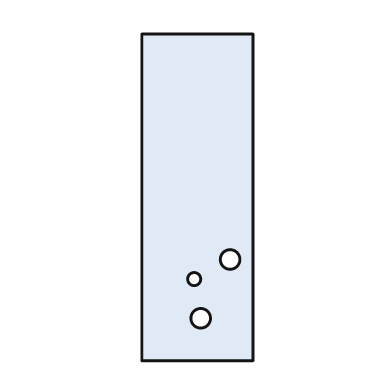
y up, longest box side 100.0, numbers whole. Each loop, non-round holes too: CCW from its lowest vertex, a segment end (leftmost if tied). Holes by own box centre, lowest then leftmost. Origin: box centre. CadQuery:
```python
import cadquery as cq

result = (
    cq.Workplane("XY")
    .moveTo(-17.0, -50.0)
    .lineTo(17.0, -50.0)
    .lineTo(17.0, 50.0)
    .lineTo(-17.0, 50.0)
    .close()
    .moveTo(1.0, -37.0)
    .circle(3.0)
    .moveTo(-1.0, -25.0)
    .circle(2.0)
    .moveTo(10.0, -19.0)
    .circle(3.0)
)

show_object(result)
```